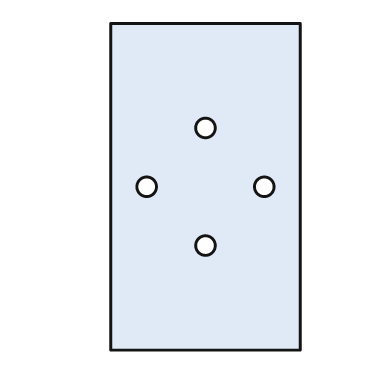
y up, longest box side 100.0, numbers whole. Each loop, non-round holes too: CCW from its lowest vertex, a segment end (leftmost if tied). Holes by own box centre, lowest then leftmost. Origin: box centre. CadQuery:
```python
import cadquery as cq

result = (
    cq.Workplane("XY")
    .moveTo(-29.0, -50.0)
    .lineTo(29.0, -50.0)
    .lineTo(29.0, 50.0)
    .lineTo(-29.0, 50.0)
    .close()
    .moveTo(0.0, -18.0)
    .circle(3.0)
    .moveTo(-18.0, 0.0)
    .circle(3.0)
    .moveTo(18.0, 0.0)
    .circle(3.0)
    .moveTo(0.0, 18.0)
    .circle(3.0)
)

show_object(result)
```